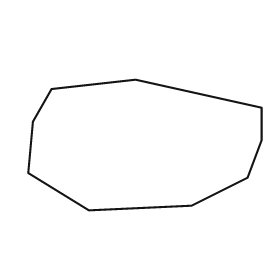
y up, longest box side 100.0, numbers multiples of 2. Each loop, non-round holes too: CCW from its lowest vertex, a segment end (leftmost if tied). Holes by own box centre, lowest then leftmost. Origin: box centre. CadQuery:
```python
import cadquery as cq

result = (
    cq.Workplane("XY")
    .moveTo(-24.0, -28.0)
    .lineTo(20.0, -26.0)
    .lineTo(44.0, -14.0)
    .lineTo(50.0, 2.0)
    .lineTo(50.0, 16.0)
    .lineTo(-4.0, 28.0)
    .lineTo(-40.0, 24.0)
    .lineTo(-48.0, 10.0)
    .lineTo(-50.0, -12.0)
    .close()
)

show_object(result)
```